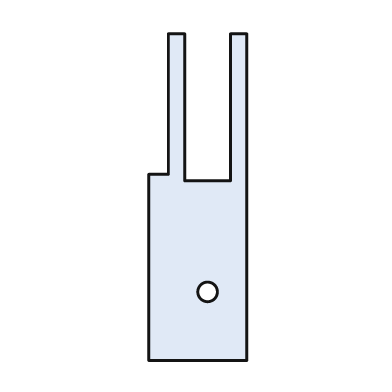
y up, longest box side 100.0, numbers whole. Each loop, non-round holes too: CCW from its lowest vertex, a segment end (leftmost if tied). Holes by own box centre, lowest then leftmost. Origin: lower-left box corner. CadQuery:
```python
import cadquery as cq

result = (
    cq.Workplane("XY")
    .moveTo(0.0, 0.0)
    .lineTo(30.0, 0.0)
    .lineTo(30.0, 100.0)
    .lineTo(25.0, 100.0)
    .lineTo(25.0, 55.0)
    .lineTo(11.0, 55.0)
    .lineTo(11.0, 100.0)
    .lineTo(6.0, 100.0)
    .lineTo(6.0, 57.0)
    .lineTo(0.0, 57.0)
    .close()
    .moveTo(18.0, 21.0)
    .circle(3.0)
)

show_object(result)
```